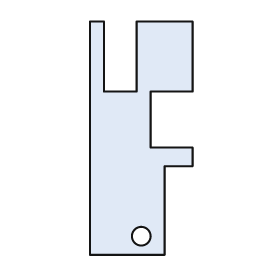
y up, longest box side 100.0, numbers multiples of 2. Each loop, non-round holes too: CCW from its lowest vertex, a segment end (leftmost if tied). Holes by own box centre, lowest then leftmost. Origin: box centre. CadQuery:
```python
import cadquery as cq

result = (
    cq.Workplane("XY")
    .moveTo(-22.0, -50.0)
    .lineTo(10.0, -50.0)
    .lineTo(10.0, -12.0)
    .lineTo(22.0, -12.0)
    .lineTo(22.0, -4.0)
    .lineTo(4.0, -4.0)
    .lineTo(4.0, 20.0)
    .lineTo(22.0, 20.0)
    .lineTo(22.0, 50.0)
    .lineTo(-2.0, 50.0)
    .lineTo(-2.0, 20.0)
    .lineTo(-16.0, 20.0)
    .lineTo(-16.0, 50.0)
    .lineTo(-22.0, 50.0)
    .close()
    .moveTo(0.0, -42.0)
    .circle(4.0)
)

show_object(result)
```